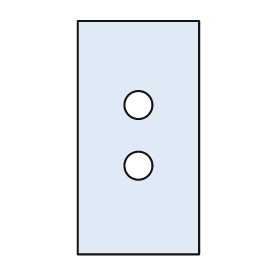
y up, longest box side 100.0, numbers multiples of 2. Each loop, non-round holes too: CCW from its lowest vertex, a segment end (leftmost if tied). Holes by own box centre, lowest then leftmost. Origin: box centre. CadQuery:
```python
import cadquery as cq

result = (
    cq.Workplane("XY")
    .moveTo(-26.0, -50.0)
    .lineTo(26.0, -50.0)
    .lineTo(26.0, 50.0)
    .lineTo(-26.0, 50.0)
    .close()
    .moveTo(0.0, -12.0)
    .circle(6.0)
    .moveTo(0.0, 14.0)
    .circle(6.0)
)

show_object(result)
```